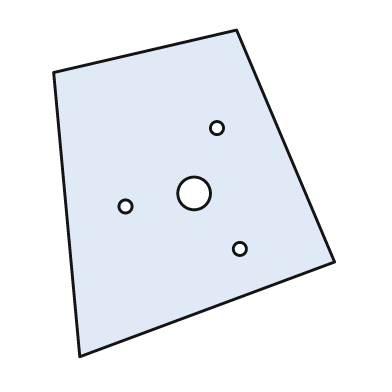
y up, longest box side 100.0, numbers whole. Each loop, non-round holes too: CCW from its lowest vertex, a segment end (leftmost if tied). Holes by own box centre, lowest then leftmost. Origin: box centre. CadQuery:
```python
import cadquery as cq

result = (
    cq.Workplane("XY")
    .moveTo(-35.0, -50.0)
    .lineTo(43.0, -21.0)
    .lineTo(13.0, 50.0)
    .lineTo(-43.0, 37.0)
    .close()
    .moveTo(14.0, -17.0)
    .circle(2.0)
    .moveTo(-21.0, -4.0)
    .circle(2.0)
    .moveTo(0.0, 0.0)
    .circle(5.0)
    .moveTo(7.0, 20.0)
    .circle(2.0)
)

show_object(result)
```